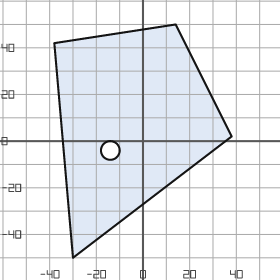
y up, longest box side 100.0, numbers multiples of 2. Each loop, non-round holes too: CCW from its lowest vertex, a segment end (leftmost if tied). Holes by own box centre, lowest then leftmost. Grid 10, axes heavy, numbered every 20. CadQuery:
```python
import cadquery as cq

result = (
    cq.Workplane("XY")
    .moveTo(-30.0, -50.0)
    .lineTo(38.0, 2.0)
    .lineTo(14.0, 50.0)
    .lineTo(-38.0, 42.0)
    .close()
    .moveTo(-14.0, -4.0)
    .circle(4.0)
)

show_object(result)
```